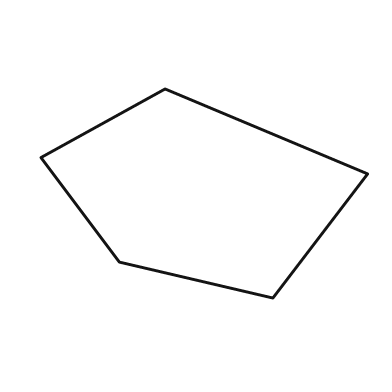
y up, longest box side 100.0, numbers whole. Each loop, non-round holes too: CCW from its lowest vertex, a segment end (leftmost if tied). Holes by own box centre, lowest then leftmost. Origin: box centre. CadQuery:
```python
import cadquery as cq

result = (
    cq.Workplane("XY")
    .moveTo(21.0, -32.0)
    .lineTo(50.0, 6.0)
    .lineTo(-12.0, 32.0)
    .lineTo(-50.0, 11.0)
    .lineTo(-26.0, -21.0)
    .close()
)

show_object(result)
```